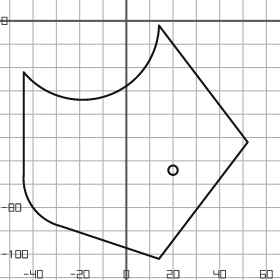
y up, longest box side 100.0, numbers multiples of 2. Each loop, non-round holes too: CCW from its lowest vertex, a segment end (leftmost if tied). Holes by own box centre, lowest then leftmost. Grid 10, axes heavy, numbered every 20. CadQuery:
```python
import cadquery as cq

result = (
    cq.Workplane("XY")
    .moveTo(14.0, -102.0)
    .lineTo(52.0, -52.0)
    .lineTo(14.0, -2.0)
    .threePointArc((-8.0, -32.0), (-44.0, -22.0))
    .lineTo(-44.0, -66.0)
    .threePointArc((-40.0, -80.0), (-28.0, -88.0))
    .close()
    .moveTo(20.0, -64.0)
    .circle(2.0)
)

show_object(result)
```